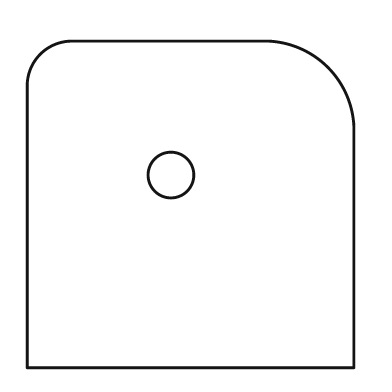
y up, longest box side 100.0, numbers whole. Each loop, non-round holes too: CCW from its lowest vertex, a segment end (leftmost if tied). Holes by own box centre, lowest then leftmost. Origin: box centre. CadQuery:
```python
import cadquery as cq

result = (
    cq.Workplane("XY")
    .moveTo(-50.0, -50.0)
    .lineTo(50.0, -50.0)
    .lineTo(50.0, 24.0)
    .threePointArc((42.0, 42.0), (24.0, 50.0))
    .lineTo(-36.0, 50.0)
    .threePointArc((-46.0, 46.0), (-50.0, 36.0))
    .close()
    .moveTo(-6.0, 9.0)
    .circle(7.0)
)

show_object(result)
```